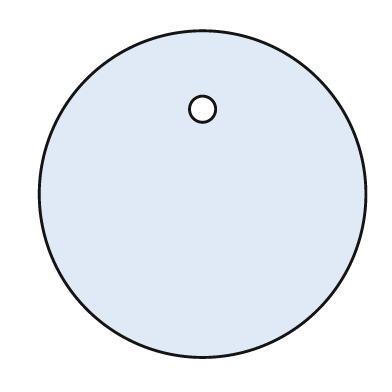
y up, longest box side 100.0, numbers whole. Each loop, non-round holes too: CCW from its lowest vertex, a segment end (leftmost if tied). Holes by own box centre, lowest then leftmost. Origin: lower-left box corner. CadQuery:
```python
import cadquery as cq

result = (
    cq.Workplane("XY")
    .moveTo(50.0, 50.0)
    .circle(50.0)
    .moveTo(50.0, 76.0)
    .circle(4.0)
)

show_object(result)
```